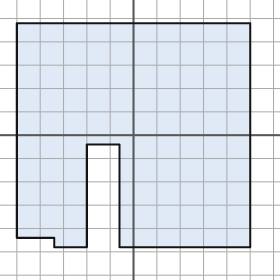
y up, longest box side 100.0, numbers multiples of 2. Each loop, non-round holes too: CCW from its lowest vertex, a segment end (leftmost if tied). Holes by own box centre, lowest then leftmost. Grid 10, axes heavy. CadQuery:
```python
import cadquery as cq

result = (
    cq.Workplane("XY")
    .moveTo(-34.0, -48.0)
    .lineTo(-20.0, -48.0)
    .lineTo(-20.0, -4.0)
    .lineTo(-6.0, -4.0)
    .lineTo(-6.0, -48.0)
    .lineTo(50.0, -48.0)
    .lineTo(50.0, 48.0)
    .lineTo(-50.0, 48.0)
    .lineTo(-50.0, -44.0)
    .lineTo(-34.0, -44.0)
    .close()
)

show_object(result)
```